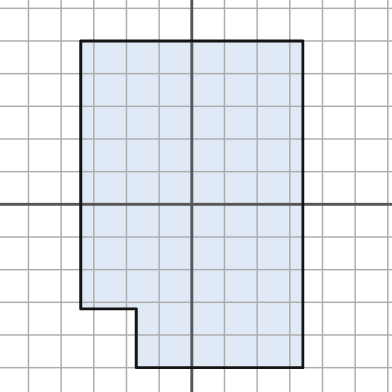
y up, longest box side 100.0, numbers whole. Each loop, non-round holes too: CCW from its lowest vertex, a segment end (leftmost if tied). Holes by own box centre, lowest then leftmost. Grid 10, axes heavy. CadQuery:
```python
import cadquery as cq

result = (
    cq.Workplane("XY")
    .moveTo(-17.0, -50.0)
    .lineTo(34.0, -50.0)
    .lineTo(34.0, 50.0)
    .lineTo(-34.0, 50.0)
    .lineTo(-34.0, -32.0)
    .lineTo(-17.0, -32.0)
    .close()
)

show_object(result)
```